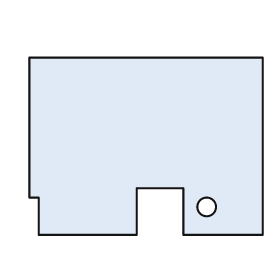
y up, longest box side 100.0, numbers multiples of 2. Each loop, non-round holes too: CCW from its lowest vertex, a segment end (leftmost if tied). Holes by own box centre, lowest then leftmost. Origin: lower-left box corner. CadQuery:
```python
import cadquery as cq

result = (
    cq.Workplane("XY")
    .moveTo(4.0, 0.0)
    .lineTo(46.0, 0.0)
    .lineTo(46.0, 20.0)
    .lineTo(66.0, 20.0)
    .lineTo(66.0, 0.0)
    .lineTo(100.0, 0.0)
    .lineTo(100.0, 76.0)
    .lineTo(0.0, 76.0)
    .lineTo(0.0, 16.0)
    .lineTo(4.0, 16.0)
    .close()
    .moveTo(76.0, 12.0)
    .circle(4.0)
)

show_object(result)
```